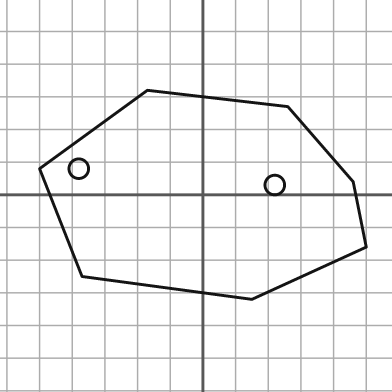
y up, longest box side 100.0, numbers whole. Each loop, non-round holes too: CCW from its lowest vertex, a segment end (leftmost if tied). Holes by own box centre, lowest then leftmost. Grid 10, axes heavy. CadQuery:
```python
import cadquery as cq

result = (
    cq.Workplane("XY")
    .moveTo(15.0, -32.0)
    .lineTo(50.0, -16.0)
    .lineTo(46.0, 4.0)
    .lineTo(26.0, 27.0)
    .lineTo(-17.0, 32.0)
    .lineTo(-50.0, 8.0)
    .lineTo(-37.0, -25.0)
    .close()
    .moveTo(22.0, 3.0)
    .circle(3.0)
    .moveTo(-38.0, 8.0)
    .circle(3.0)
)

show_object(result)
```